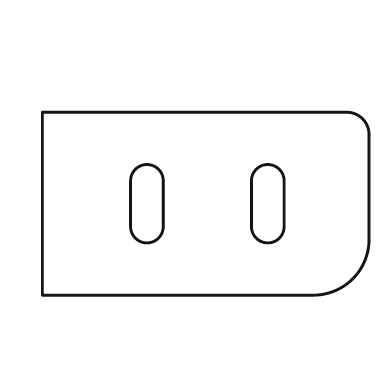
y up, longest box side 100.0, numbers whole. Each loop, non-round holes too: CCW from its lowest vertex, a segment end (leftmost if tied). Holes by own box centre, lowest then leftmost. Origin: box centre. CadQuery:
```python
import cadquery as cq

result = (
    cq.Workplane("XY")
    .moveTo(-50.0, -28.0)
    .lineTo(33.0, -28.0)
    .threePointArc((45.0, -23.0), (50.0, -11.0))
    .lineTo(50.0, 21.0)
    .threePointArc((48.0, 26.0), (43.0, 28.0))
    .lineTo(-50.0, 28.0)
    .close()
    .moveTo(-23.0, -7.0)
    .threePointArc((-18.0, -12.0), (-13.0, -7.0))
    .lineTo(-13.0, 7.0)
    .threePointArc((-18.0, 12.0), (-23.0, 7.0))
    .close()
    .moveTo(14.0, -7.0)
    .threePointArc((19.0, -12.0), (24.0, -7.0))
    .lineTo(24.0, 7.0)
    .threePointArc((19.0, 12.0), (14.0, 7.0))
    .close()
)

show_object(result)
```